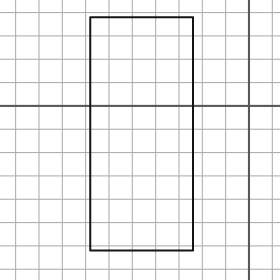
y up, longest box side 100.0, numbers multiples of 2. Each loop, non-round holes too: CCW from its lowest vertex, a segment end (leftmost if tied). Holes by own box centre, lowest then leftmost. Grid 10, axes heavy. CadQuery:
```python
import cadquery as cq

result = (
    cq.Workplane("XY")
    .moveTo(-68.0, -62.0)
    .lineTo(-24.0, -62.0)
    .lineTo(-24.0, 38.0)
    .lineTo(-68.0, 38.0)
    .close()
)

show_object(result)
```